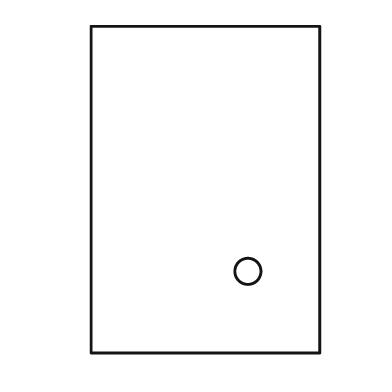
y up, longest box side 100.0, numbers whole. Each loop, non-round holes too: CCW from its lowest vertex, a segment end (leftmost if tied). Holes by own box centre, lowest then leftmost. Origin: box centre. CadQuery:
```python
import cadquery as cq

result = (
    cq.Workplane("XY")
    .moveTo(-35.0, -50.0)
    .lineTo(35.0, -50.0)
    .lineTo(35.0, 50.0)
    .lineTo(-35.0, 50.0)
    .close()
    .moveTo(13.0, -25.0)
    .circle(4.0)
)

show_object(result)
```